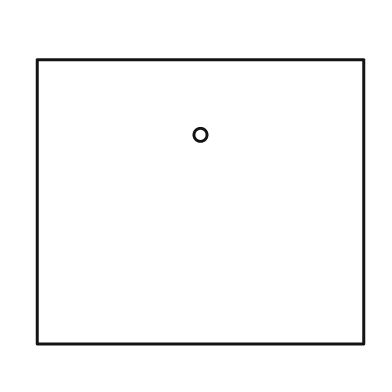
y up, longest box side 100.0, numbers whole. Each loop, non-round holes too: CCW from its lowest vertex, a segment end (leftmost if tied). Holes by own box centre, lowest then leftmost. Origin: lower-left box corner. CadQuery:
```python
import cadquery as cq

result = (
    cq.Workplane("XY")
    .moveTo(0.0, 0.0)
    .lineTo(100.0, 0.0)
    .lineTo(100.0, 87.0)
    .lineTo(0.0, 87.0)
    .close()
    .moveTo(50.0, 64.0)
    .circle(2.0)
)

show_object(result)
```